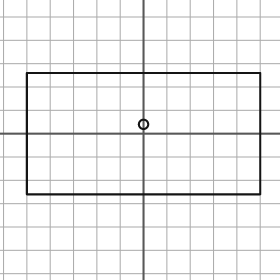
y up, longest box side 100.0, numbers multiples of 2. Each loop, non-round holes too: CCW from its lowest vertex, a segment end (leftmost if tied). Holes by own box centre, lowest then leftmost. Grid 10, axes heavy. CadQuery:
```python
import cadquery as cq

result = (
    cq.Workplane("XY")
    .moveTo(-50.0, -26.0)
    .lineTo(50.0, -26.0)
    .lineTo(50.0, 26.0)
    .lineTo(-50.0, 26.0)
    .close()
    .moveTo(0.0, 4.0)
    .circle(2.0)
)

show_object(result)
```